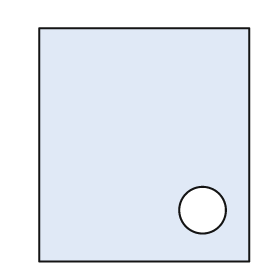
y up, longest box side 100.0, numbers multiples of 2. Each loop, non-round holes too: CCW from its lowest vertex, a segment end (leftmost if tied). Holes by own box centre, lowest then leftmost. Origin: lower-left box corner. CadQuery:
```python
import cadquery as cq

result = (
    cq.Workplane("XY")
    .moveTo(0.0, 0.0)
    .lineTo(90.0, 0.0)
    .lineTo(90.0, 100.0)
    .lineTo(0.0, 100.0)
    .close()
    .moveTo(70.0, 22.0)
    .circle(10.0)
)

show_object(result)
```